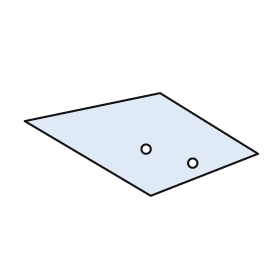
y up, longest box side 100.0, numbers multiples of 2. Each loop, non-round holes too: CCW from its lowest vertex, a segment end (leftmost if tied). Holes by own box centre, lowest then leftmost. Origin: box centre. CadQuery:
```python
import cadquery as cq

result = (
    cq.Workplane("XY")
    .moveTo(4.0, -22.0)
    .lineTo(50.0, -4.0)
    .lineTo(8.0, 22.0)
    .lineTo(-50.0, 10.0)
    .close()
    .moveTo(22.0, -8.0)
    .circle(2.0)
    .moveTo(2.0, -2.0)
    .circle(2.0)
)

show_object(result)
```